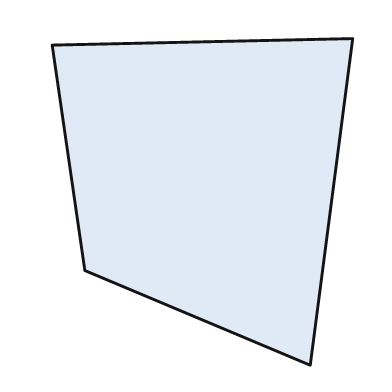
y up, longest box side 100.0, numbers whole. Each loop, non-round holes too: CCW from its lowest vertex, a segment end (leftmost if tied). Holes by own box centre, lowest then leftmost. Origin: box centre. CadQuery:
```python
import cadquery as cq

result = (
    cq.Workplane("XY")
    .moveTo(33.0, -50.0)
    .lineTo(46.0, 50.0)
    .lineTo(-46.0, 48.0)
    .lineTo(-36.0, -21.0)
    .close()
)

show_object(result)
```